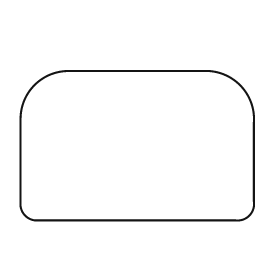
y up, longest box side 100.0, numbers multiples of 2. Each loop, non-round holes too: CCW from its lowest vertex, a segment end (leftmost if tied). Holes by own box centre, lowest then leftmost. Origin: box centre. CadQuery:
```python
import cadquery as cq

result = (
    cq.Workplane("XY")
    .moveTo(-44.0, -32.0)
    .lineTo(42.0, -32.0)
    .threePointArc((48.0, -30.0), (50.0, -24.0))
    .lineTo(50.0, 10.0)
    .threePointArc((44.0, 26.0), (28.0, 32.0))
    .lineTo(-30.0, 32.0)
    .threePointArc((-44.0, 26.0), (-50.0, 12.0))
    .lineTo(-50.0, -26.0)
    .threePointArc((-48.0, -30.0), (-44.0, -32.0))
    .close()
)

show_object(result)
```